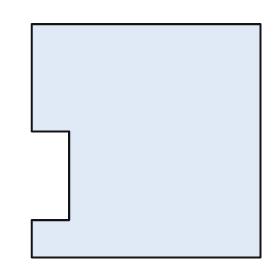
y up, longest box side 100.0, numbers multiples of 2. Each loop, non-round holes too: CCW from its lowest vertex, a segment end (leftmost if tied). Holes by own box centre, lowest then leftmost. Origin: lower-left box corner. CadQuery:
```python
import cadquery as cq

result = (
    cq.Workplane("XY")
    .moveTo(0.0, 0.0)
    .lineTo(98.0, 0.0)
    .lineTo(98.0, 100.0)
    .lineTo(0.0, 100.0)
    .lineTo(0.0, 54.0)
    .lineTo(16.0, 54.0)
    .lineTo(16.0, 16.0)
    .lineTo(0.0, 16.0)
    .close()
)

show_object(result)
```